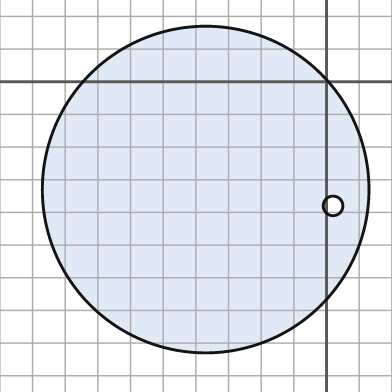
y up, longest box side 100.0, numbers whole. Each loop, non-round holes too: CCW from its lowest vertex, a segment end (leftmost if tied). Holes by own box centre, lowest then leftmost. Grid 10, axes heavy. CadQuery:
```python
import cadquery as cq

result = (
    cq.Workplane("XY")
    .moveTo(-37.0, -33.0)
    .circle(50.0)
    .moveTo(2.0, -38.0)
    .circle(3.0)
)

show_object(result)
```